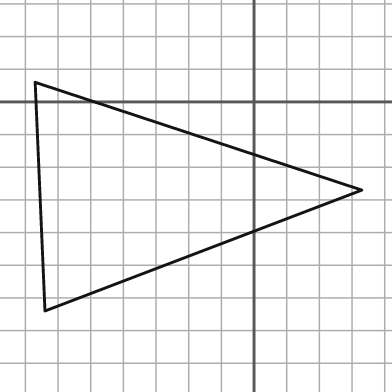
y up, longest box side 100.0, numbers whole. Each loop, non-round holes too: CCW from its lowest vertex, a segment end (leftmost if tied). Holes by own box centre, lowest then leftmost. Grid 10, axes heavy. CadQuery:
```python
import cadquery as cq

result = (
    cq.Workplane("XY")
    .moveTo(-64.0, -64.0)
    .lineTo(33.0, -27.0)
    .lineTo(-67.0, 6.0)
    .close()
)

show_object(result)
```